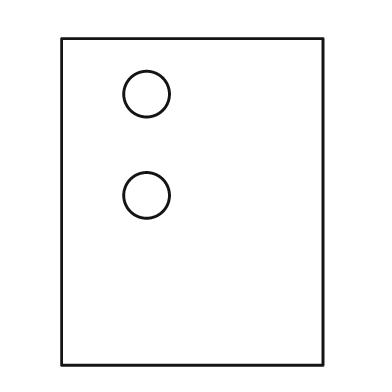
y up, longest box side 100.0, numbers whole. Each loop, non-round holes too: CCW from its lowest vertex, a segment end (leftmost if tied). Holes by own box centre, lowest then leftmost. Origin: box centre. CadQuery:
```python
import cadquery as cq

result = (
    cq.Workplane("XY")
    .moveTo(-40.0, -50.0)
    .lineTo(40.0, -50.0)
    .lineTo(40.0, 50.0)
    .lineTo(-40.0, 50.0)
    .close()
    .moveTo(-14.0, 2.0)
    .circle(7.0)
    .moveTo(-14.0, 33.0)
    .circle(7.0)
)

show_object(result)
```